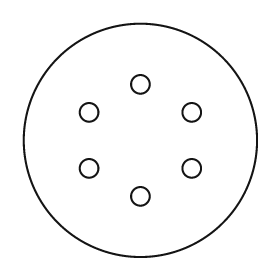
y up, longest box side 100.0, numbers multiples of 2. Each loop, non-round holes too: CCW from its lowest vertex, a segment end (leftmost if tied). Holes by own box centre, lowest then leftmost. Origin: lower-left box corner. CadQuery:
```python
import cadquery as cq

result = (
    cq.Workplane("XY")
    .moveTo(50.0, 50.0)
    .circle(50.0)
    .moveTo(50.0, 26.0)
    .circle(4.0)
    .moveTo(28.0, 38.0)
    .circle(4.0)
    .moveTo(72.0, 38.0)
    .circle(4.0)
    .moveTo(28.0, 62.0)
    .circle(4.0)
    .moveTo(72.0, 62.0)
    .circle(4.0)
    .moveTo(50.0, 74.0)
    .circle(4.0)
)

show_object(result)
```